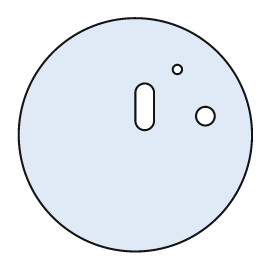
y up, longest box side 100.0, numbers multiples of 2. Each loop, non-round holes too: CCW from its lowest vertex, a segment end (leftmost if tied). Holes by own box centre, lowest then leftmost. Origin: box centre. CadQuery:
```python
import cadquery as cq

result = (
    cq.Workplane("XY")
    .moveTo(0.0, 0.0)
    .circle(50.0)
    .moveTo(30.0, 8.0)
    .circle(4.0)
    .moveTo(0.0, 6.0)
    .threePointArc((4.0, 2.0), (8.0, 6.0))
    .lineTo(8.0, 18.0)
    .threePointArc((4.0, 22.0), (0.0, 18.0))
    .close()
    .moveTo(18.0, 28.0)
    .circle(2.0)
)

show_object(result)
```